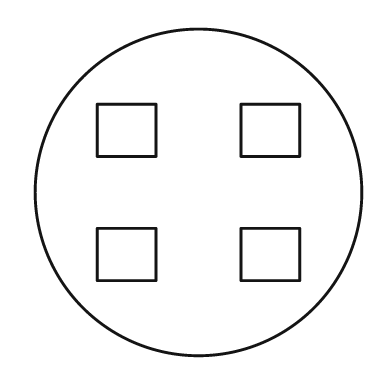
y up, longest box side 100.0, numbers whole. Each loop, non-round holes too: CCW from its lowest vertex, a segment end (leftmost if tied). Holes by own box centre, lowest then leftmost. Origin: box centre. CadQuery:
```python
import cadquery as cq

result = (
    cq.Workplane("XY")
    .moveTo(0.0, 0.0)
    .circle(50.0)
    .moveTo(-31.0, -27.0)
    .lineTo(-13.0, -27.0)
    .lineTo(-13.0, -11.0)
    .lineTo(-31.0, -11.0)
    .close()
    .moveTo(13.0, -27.0)
    .lineTo(31.0, -27.0)
    .lineTo(31.0, -11.0)
    .lineTo(13.0, -11.0)
    .close()
    .moveTo(-31.0, 11.0)
    .lineTo(-13.0, 11.0)
    .lineTo(-13.0, 27.0)
    .lineTo(-31.0, 27.0)
    .close()
    .moveTo(13.0, 11.0)
    .lineTo(31.0, 11.0)
    .lineTo(31.0, 27.0)
    .lineTo(13.0, 27.0)
    .close()
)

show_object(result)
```